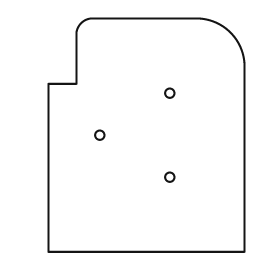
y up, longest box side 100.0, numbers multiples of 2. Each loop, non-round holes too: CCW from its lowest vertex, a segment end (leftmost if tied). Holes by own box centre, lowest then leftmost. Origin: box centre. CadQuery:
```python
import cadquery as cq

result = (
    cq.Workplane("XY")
    .moveTo(-42.0, -50.0)
    .lineTo(42.0, -50.0)
    .lineTo(42.0, 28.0)
    .threePointArc((36.0, 44.0), (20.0, 50.0))
    .lineTo(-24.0, 50.0)
    .threePointArc((-28.0, 48.0), (-30.0, 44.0))
    .lineTo(-30.0, 22.0)
    .lineTo(-42.0, 22.0)
    .close()
    .moveTo(10.0, -18.0)
    .circle(2.0)
    .moveTo(-20.0, 0.0)
    .circle(2.0)
    .moveTo(10.0, 18.0)
    .circle(2.0)
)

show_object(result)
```